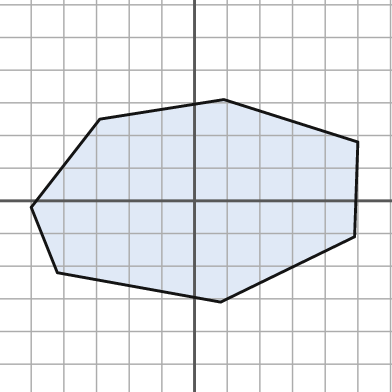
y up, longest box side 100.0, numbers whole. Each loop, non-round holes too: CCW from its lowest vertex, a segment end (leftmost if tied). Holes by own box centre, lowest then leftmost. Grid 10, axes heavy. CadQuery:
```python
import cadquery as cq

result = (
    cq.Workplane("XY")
    .moveTo(8.0, -31.0)
    .lineTo(49.0, -11.0)
    .lineTo(50.0, 18.0)
    .lineTo(9.0, 31.0)
    .lineTo(-29.0, 25.0)
    .lineTo(-50.0, -2.0)
    .lineTo(-42.0, -22.0)
    .close()
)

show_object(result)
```